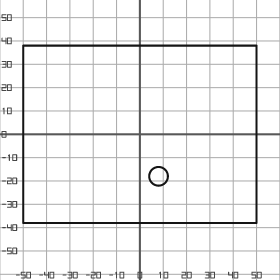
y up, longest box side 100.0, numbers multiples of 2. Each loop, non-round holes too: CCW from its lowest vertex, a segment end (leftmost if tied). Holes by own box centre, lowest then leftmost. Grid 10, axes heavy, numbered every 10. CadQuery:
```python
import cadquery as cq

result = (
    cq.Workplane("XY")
    .moveTo(-50.0, -38.0)
    .lineTo(50.0, -38.0)
    .lineTo(50.0, 38.0)
    .lineTo(-50.0, 38.0)
    .close()
    .moveTo(8.0, -18.0)
    .circle(4.0)
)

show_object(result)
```